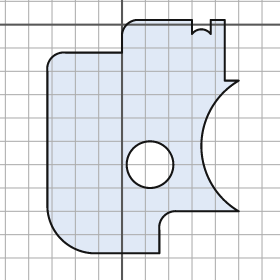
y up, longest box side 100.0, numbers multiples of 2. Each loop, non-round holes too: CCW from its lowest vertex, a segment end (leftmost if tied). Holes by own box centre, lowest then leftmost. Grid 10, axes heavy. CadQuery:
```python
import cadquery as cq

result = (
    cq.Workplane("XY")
    .moveTo(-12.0, -98.0)
    .lineTo(16.0, -98.0)
    .lineTo(16.0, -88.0)
    .threePointArc((18.0, -82.0), (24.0, -80.0))
    .lineTo(50.0, -80.0)
    .threePointArc((34.0, -52.0), (50.0, -24.0))
    .lineTo(44.0, -24.0)
    .lineTo(44.0, 2.0)
    .lineTo(38.0, 2.0)
    .lineTo(38.0, -4.0)
    .threePointArc((34.0, -2.0), (30.0, -4.0))
    .lineTo(30.0, 2.0)
    .lineTo(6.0, 2.0)
    .threePointArc((2.0, 0.0), (0.0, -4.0))
    .lineTo(0.0, -12.0)
    .lineTo(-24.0, -12.0)
    .threePointArc((-30.0, -14.0), (-32.0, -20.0))
    .lineTo(-32.0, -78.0)
    .threePointArc((-26.0, -92.0), (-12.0, -98.0))
    .close()
    .moveTo(12.0, -60.0)
    .circle(10.0)
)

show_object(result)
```